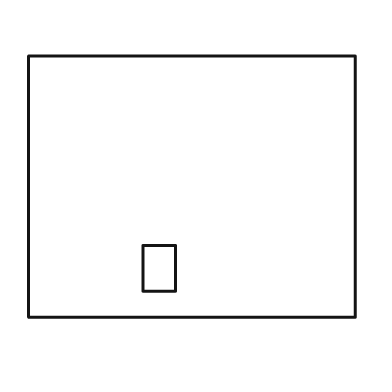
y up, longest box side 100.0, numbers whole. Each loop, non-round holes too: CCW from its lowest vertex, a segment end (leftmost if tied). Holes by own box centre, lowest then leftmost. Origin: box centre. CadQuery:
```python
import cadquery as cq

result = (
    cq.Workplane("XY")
    .moveTo(-50.0, -40.0)
    .lineTo(50.0, -40.0)
    .lineTo(50.0, 40.0)
    .lineTo(-50.0, 40.0)
    .close()
    .moveTo(-15.0, -32.0)
    .lineTo(-5.0, -32.0)
    .lineTo(-5.0, -18.0)
    .lineTo(-15.0, -18.0)
    .close()
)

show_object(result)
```